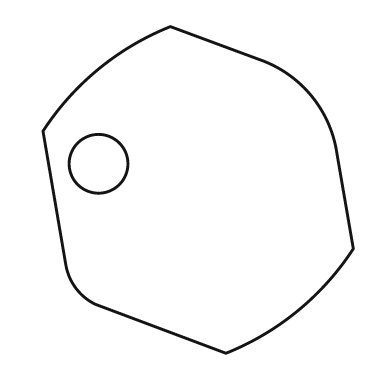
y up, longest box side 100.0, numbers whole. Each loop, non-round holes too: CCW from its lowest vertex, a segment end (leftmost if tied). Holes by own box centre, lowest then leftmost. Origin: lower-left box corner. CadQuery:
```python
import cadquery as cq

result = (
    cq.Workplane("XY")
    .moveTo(56.0, 0.0)
    .threePointArc((78.0, 13.0), (95.0, 32.0))
    .lineTo(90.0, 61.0)
    .threePointArc((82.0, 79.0), (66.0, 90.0))
    .lineTo(39.0, 100.0)
    .threePointArc((17.0, 87.0), (0.0, 68.0))
    .lineTo(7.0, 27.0)
    .threePointArc((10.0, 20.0), (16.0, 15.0))
    .close()
    .moveTo(17.0, 58.0)
    .circle(9.0)
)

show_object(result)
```